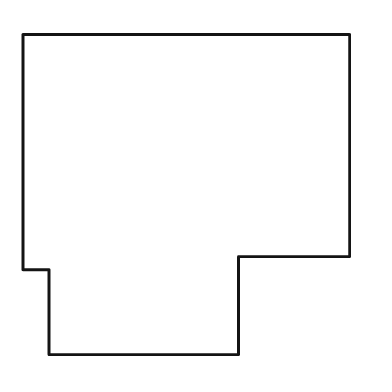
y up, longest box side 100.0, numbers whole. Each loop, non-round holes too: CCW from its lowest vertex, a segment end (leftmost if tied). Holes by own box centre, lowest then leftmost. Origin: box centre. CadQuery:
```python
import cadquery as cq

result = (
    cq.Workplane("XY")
    .moveTo(-42.0, -49.0)
    .lineTo(16.0, -49.0)
    .lineTo(16.0, -19.0)
    .lineTo(50.0, -19.0)
    .lineTo(50.0, 49.0)
    .lineTo(-50.0, 49.0)
    .lineTo(-50.0, -23.0)
    .lineTo(-42.0, -23.0)
    .close()
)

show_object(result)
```